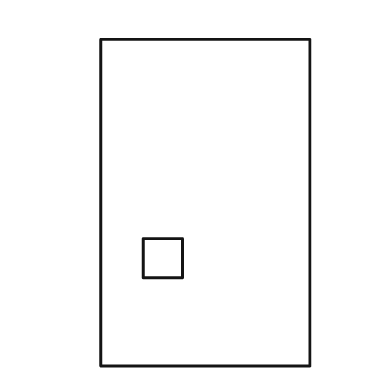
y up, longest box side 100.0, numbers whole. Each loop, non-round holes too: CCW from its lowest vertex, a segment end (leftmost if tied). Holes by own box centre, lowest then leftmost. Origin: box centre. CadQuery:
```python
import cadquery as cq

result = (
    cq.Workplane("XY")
    .moveTo(-32.0, -50.0)
    .lineTo(32.0, -50.0)
    .lineTo(32.0, 50.0)
    .lineTo(-32.0, 50.0)
    .close()
    .moveTo(-19.0, -23.0)
    .lineTo(-7.0, -23.0)
    .lineTo(-7.0, -11.0)
    .lineTo(-19.0, -11.0)
    .close()
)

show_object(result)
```